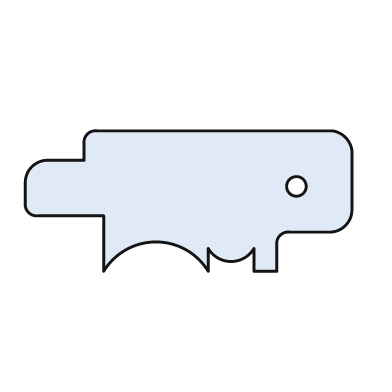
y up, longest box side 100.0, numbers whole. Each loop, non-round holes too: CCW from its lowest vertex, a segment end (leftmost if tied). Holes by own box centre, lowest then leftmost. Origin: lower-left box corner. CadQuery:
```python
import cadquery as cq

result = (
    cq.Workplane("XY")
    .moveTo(24.0, 0.0)
    .threePointArc((40.0, 9.0), (56.0, 0.0))
    .lineTo(56.0, 7.0)
    .threePointArc((63.0, 3.0), (70.0, 7.0))
    .lineTo(70.0, 0.0)
    .lineTo(77.0, 0.0)
    .lineTo(77.0, 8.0)
    .threePointArc((78.0, 11.0), (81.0, 12.0))
    .lineTo(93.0, 12.0)
    .threePointArc((98.0, 14.0), (100.0, 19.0))
    .lineTo(100.0, 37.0)
    .threePointArc((98.0, 41.0), (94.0, 43.0))
    .lineTo(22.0, 43.0)
    .threePointArc((19.0, 42.0), (18.0, 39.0))
    .lineTo(18.0, 34.0)
    .lineTo(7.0, 34.0)
    .threePointArc((2.0, 32.0), (0.0, 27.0))
    .lineTo(0.0, 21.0)
    .threePointArc((1.0, 18.0), (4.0, 17.0))
    .lineTo(24.0, 17.0)
    .close()
    .moveTo(83.0, 26.0)
    .circle(3.0)
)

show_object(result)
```